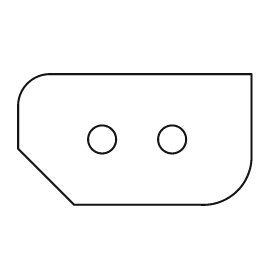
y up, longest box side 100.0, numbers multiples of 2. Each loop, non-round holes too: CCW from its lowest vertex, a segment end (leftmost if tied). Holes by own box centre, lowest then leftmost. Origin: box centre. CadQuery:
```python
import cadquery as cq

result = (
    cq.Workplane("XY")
    .moveTo(-26.0, -28.0)
    .lineTo(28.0, -28.0)
    .threePointArc((44.0, -22.0), (50.0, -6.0))
    .lineTo(50.0, 28.0)
    .lineTo(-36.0, 28.0)
    .threePointArc((-46.0, 24.0), (-50.0, 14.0))
    .lineTo(-50.0, -4.0)
    .close()
    .moveTo(-14.0, 0.0)
    .circle(6.0)
    .moveTo(16.0, 0.0)
    .circle(6.0)
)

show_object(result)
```